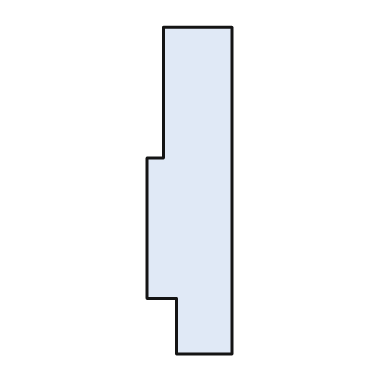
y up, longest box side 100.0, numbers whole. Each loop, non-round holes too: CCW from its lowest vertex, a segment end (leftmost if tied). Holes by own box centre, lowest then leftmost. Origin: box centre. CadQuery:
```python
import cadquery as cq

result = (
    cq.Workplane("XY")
    .moveTo(-4.0, -50.0)
    .lineTo(13.0, -50.0)
    .lineTo(13.0, 50.0)
    .lineTo(-8.0, 50.0)
    .lineTo(-8.0, 10.0)
    .lineTo(-13.0, 10.0)
    .lineTo(-13.0, -33.0)
    .lineTo(-4.0, -33.0)
    .close()
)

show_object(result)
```